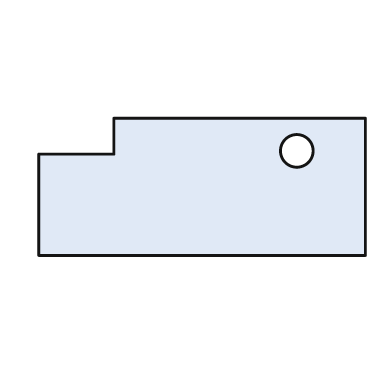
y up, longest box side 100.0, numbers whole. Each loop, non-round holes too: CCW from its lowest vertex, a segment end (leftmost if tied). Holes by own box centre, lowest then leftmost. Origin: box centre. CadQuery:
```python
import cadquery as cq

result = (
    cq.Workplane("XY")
    .moveTo(-50.0, -21.0)
    .lineTo(50.0, -21.0)
    .lineTo(50.0, 21.0)
    .lineTo(-27.0, 21.0)
    .lineTo(-27.0, 10.0)
    .lineTo(-50.0, 10.0)
    .close()
    .moveTo(29.0, 11.0)
    .circle(5.0)
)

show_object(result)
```